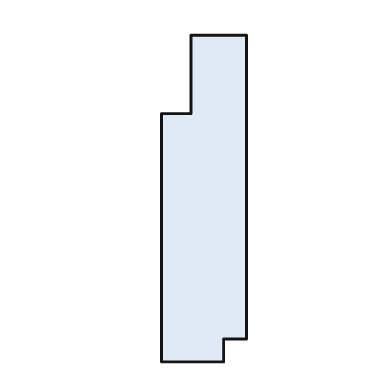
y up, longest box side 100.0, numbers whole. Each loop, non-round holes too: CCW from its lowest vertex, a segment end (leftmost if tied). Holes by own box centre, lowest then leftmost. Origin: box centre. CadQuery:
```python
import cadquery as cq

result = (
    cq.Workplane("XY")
    .moveTo(-13.0, -50.0)
    .lineTo(6.0, -50.0)
    .lineTo(6.0, -43.0)
    .lineTo(13.0, -43.0)
    .lineTo(13.0, 50.0)
    .lineTo(-4.0, 50.0)
    .lineTo(-4.0, 26.0)
    .lineTo(-13.0, 26.0)
    .close()
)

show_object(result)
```